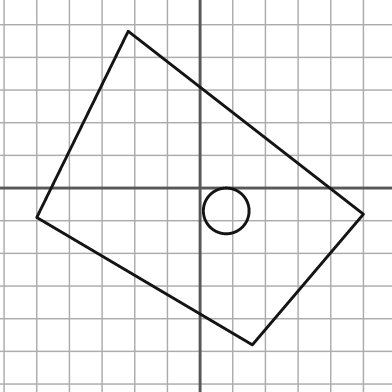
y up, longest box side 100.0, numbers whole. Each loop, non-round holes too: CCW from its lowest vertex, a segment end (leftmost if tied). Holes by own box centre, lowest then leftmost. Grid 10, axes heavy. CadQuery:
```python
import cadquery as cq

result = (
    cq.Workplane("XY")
    .moveTo(16.0, -48.0)
    .lineTo(50.0, -8.0)
    .lineTo(-22.0, 48.0)
    .lineTo(-50.0, -9.0)
    .close()
    .moveTo(8.0, -7.0)
    .circle(7.0)
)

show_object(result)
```